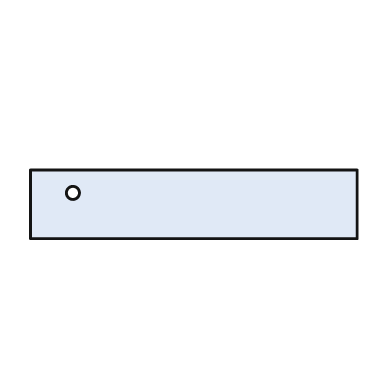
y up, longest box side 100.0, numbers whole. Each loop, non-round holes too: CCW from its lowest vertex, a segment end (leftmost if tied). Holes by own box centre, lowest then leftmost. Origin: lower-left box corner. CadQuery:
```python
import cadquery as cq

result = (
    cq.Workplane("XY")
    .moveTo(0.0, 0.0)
    .lineTo(100.0, 0.0)
    .lineTo(100.0, 21.0)
    .lineTo(0.0, 21.0)
    .close()
    .moveTo(13.0, 14.0)
    .circle(2.0)
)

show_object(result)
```